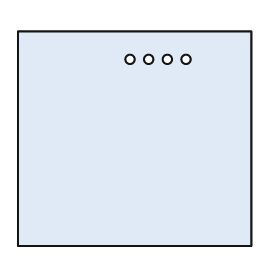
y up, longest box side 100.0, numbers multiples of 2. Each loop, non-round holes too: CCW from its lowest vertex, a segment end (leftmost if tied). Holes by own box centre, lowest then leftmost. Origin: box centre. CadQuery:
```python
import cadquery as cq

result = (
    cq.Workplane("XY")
    .moveTo(-50.0, -46.0)
    .lineTo(50.0, -46.0)
    .lineTo(50.0, 46.0)
    .lineTo(-50.0, 46.0)
    .close()
    .moveTo(-2.0, 34.0)
    .circle(2.0)
    .moveTo(6.0, 34.0)
    .circle(2.0)
    .moveTo(14.0, 34.0)
    .circle(2.0)
    .moveTo(22.0, 34.0)
    .circle(2.0)
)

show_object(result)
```